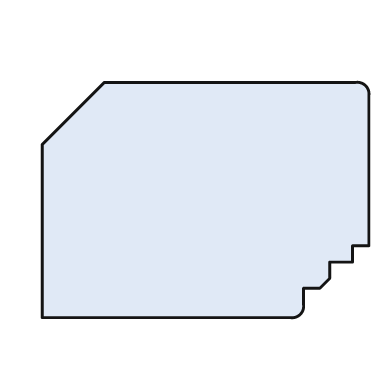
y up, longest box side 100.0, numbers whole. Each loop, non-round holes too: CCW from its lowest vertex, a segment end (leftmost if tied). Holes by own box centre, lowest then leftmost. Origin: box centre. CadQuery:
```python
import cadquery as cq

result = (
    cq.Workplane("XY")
    .moveTo(-50.0, -36.0)
    .lineTo(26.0, -36.0)
    .threePointArc((29.0, -35.0), (30.0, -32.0))
    .lineTo(30.0, -27.0)
    .lineTo(35.0, -27.0)
    .lineTo(38.0, -24.0)
    .lineTo(38.0, -19.0)
    .lineTo(45.0, -19.0)
    .lineTo(45.0, -14.0)
    .lineTo(50.0, -14.0)
    .lineTo(50.0, 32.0)
    .threePointArc((49.0, 35.0), (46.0, 36.0))
    .lineTo(-31.0, 36.0)
    .lineTo(-50.0, 17.0)
    .close()
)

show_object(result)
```